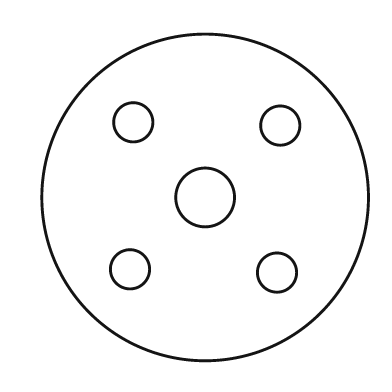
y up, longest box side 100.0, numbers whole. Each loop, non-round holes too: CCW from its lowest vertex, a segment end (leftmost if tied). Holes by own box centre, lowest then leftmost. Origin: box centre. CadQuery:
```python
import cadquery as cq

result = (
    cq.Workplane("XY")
    .moveTo(0.0, 0.0)
    .circle(50.0)
    .moveTo(22.0, -23.0)
    .circle(6.0)
    .moveTo(-23.0, -22.0)
    .circle(6.0)
    .moveTo(0.0, 0.0)
    .circle(9.0)
    .moveTo(23.0, 22.0)
    .circle(6.0)
    .moveTo(-22.0, 23.0)
    .circle(6.0)
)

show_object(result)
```